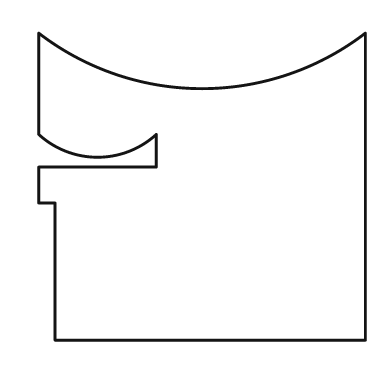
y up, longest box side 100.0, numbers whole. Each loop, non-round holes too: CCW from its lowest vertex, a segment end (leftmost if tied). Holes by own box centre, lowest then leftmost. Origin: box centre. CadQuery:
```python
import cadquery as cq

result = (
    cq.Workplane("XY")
    .moveTo(-45.0, -47.0)
    .lineTo(50.0, -47.0)
    .lineTo(50.0, 47.0)
    .threePointArc((0.0, 30.0), (-50.0, 47.0))
    .lineTo(-50.0, 16.0)
    .threePointArc((-32.0, 9.0), (-14.0, 16.0))
    .lineTo(-14.0, 6.0)
    .lineTo(-50.0, 6.0)
    .lineTo(-50.0, -5.0)
    .lineTo(-45.0, -5.0)
    .close()
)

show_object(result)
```